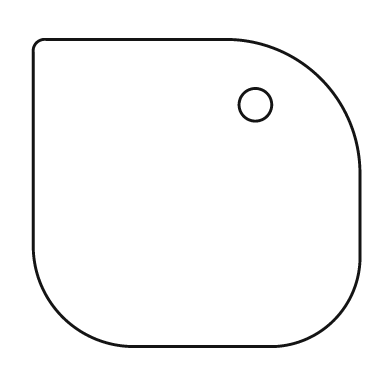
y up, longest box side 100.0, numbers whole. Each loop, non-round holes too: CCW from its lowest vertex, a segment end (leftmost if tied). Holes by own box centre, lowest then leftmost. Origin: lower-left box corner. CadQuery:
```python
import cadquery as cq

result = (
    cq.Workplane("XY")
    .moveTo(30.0, 0.0)
    .lineTo(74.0, 0.0)
    .threePointArc((92.0, 8.0), (100.0, 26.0))
    .lineTo(100.0, 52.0)
    .threePointArc((88.0, 82.0), (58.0, 94.0))
    .lineTo(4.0, 94.0)
    .threePointArc((1.0, 93.0), (0.0, 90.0))
    .lineTo(0.0, 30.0)
    .threePointArc((9.0, 9.0), (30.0, 0.0))
    .close()
    .moveTo(68.0, 74.0)
    .circle(5.0)
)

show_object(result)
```